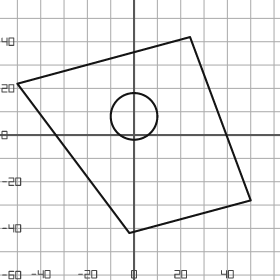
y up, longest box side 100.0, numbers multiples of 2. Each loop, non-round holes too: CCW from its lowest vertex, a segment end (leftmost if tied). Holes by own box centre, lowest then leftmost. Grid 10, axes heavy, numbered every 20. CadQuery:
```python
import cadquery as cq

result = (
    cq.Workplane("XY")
    .moveTo(-2.0, -42.0)
    .lineTo(50.0, -28.0)
    .lineTo(24.0, 42.0)
    .lineTo(-50.0, 22.0)
    .close()
    .moveTo(0.0, 8.0)
    .circle(10.0)
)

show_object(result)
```